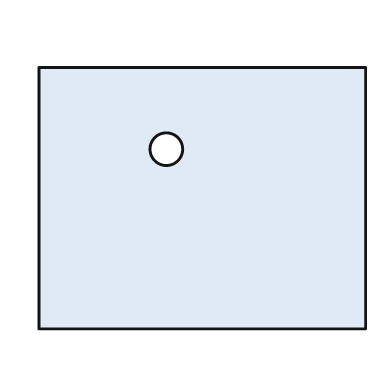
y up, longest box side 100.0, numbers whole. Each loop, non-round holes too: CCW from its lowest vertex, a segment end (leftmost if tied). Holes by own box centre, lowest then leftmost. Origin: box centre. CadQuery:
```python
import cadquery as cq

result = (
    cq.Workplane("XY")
    .moveTo(-50.0, -40.0)
    .lineTo(50.0, -40.0)
    .lineTo(50.0, 40.0)
    .lineTo(-50.0, 40.0)
    .close()
    .moveTo(-11.0, 15.0)
    .circle(5.0)
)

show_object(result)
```